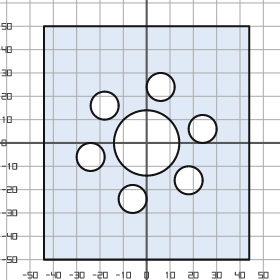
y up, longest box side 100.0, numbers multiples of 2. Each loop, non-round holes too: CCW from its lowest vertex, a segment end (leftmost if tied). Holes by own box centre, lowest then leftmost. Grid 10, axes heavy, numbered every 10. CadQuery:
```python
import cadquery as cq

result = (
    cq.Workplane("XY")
    .moveTo(-44.0, -50.0)
    .lineTo(44.0, -50.0)
    .lineTo(44.0, 50.0)
    .lineTo(-44.0, 50.0)
    .close()
    .moveTo(-6.0, -24.0)
    .circle(6.0)
    .moveTo(18.0, -16.0)
    .circle(6.0)
    .moveTo(-24.0, -6.0)
    .circle(6.0)
    .moveTo(0.0, 0.0)
    .circle(14.0)
    .moveTo(24.0, 6.0)
    .circle(6.0)
    .moveTo(-18.0, 16.0)
    .circle(6.0)
    .moveTo(6.0, 24.0)
    .circle(6.0)
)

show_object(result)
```